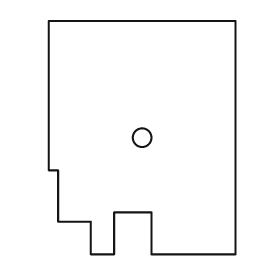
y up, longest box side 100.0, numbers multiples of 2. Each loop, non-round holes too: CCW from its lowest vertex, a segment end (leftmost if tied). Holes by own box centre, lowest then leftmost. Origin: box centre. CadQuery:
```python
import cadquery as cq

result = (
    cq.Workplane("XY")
    .moveTo(-22.0, -50.0)
    .lineTo(-12.0, -50.0)
    .lineTo(-12.0, -32.0)
    .lineTo(4.0, -32.0)
    .lineTo(4.0, -50.0)
    .lineTo(40.0, -50.0)
    .lineTo(40.0, 50.0)
    .lineTo(-40.0, 50.0)
    .lineTo(-40.0, -14.0)
    .lineTo(-36.0, -14.0)
    .lineTo(-36.0, -36.0)
    .lineTo(-22.0, -36.0)
    .close()
    .moveTo(0.0, 0.0)
    .circle(4.0)
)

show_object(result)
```